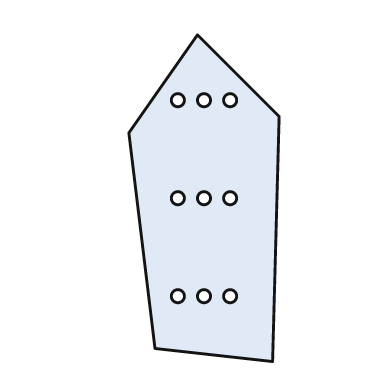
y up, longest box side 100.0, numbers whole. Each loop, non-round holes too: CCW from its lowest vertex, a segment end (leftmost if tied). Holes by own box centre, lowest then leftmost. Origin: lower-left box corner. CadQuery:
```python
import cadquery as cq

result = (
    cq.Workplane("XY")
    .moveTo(44.0, 0.0)
    .lineTo(46.0, 75.0)
    .lineTo(21.0, 100.0)
    .lineTo(0.0, 70.0)
    .lineTo(8.0, 4.0)
    .close()
    .moveTo(15.0, 20.0)
    .circle(2.0)
    .moveTo(23.0, 20.0)
    .circle(2.0)
    .moveTo(31.0, 20.0)
    .circle(2.0)
    .moveTo(15.0, 50.0)
    .circle(2.0)
    .moveTo(23.0, 50.0)
    .circle(2.0)
    .moveTo(31.0, 50.0)
    .circle(2.0)
    .moveTo(15.0, 80.0)
    .circle(2.0)
    .moveTo(23.0, 80.0)
    .circle(2.0)
    .moveTo(31.0, 80.0)
    .circle(2.0)
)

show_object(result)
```